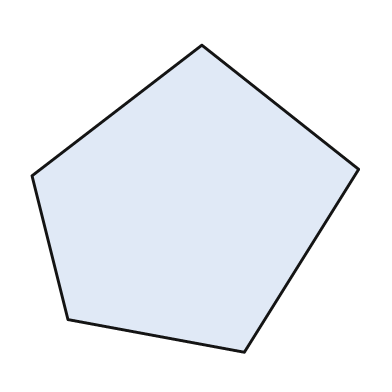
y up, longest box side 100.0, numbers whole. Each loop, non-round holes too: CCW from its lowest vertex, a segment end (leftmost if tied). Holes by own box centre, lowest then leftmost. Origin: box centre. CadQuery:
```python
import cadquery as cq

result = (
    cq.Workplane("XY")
    .moveTo(15.0, -47.0)
    .lineTo(50.0, 9.0)
    .lineTo(2.0, 47.0)
    .lineTo(-50.0, 7.0)
    .lineTo(-39.0, -37.0)
    .close()
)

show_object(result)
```